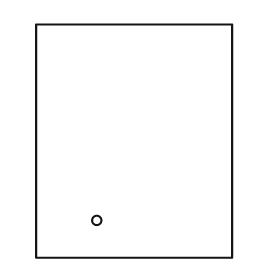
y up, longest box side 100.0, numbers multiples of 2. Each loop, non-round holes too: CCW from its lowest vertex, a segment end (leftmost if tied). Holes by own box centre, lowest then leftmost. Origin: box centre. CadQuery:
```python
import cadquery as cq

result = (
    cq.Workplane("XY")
    .moveTo(-42.0, -50.0)
    .lineTo(42.0, -50.0)
    .lineTo(42.0, 50.0)
    .lineTo(-42.0, 50.0)
    .close()
    .moveTo(-16.0, -34.0)
    .circle(2.0)
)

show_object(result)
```